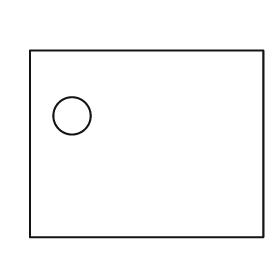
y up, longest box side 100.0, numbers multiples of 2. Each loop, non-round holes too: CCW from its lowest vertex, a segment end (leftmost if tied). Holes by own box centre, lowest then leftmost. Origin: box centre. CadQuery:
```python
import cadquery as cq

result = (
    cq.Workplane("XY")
    .moveTo(-50.0, -40.0)
    .lineTo(50.0, -40.0)
    .lineTo(50.0, 40.0)
    .lineTo(-50.0, 40.0)
    .close()
    .moveTo(-32.0, 12.0)
    .circle(8.0)
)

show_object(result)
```